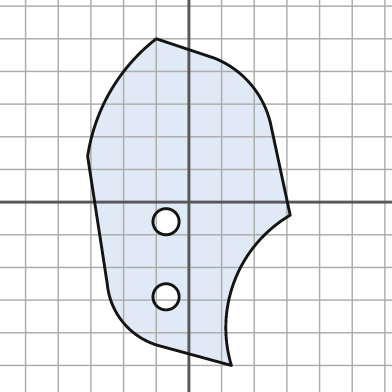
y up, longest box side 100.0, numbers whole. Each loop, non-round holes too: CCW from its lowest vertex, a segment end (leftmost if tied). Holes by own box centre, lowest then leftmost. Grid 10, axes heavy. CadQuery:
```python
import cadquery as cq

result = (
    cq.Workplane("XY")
    .moveTo(13.0, -50.0)
    .threePointArc((14.0, -24.0), (31.0, -4.0))
    .lineTo(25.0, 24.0)
    .threePointArc((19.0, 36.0), (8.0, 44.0))
    .lineTo(-10.0, 50.0)
    .threePointArc((-24.0, 34.0), (-31.0, 14.0))
    .lineTo(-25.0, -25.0)
    .threePointArc((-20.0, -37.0), (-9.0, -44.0))
    .close()
    .moveTo(-7.0, -29.0)
    .circle(4.0)
    .moveTo(-7.0, -6.0)
    .circle(4.0)
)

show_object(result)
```